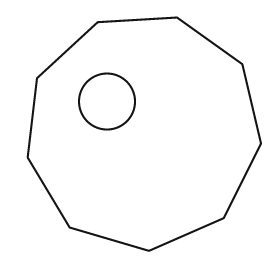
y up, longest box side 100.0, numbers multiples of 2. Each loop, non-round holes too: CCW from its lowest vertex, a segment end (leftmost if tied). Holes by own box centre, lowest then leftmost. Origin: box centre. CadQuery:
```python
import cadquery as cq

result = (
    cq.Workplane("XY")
    .moveTo(2.0, -50.0)
    .lineTo(34.0, -36.0)
    .lineTo(50.0, -4.0)
    .lineTo(42.0, 30.0)
    .lineTo(14.0, 50.0)
    .lineTo(-20.0, 48.0)
    .lineTo(-46.0, 24.0)
    .lineTo(-50.0, -10.0)
    .lineTo(-32.0, -40.0)
    .close()
    .moveTo(-16.0, 14.0)
    .circle(12.0)
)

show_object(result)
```